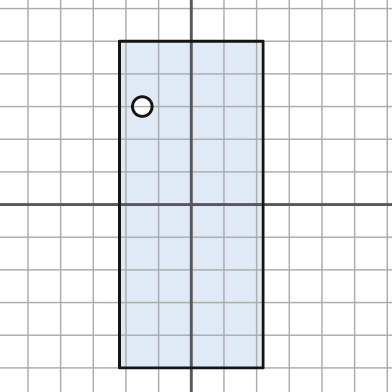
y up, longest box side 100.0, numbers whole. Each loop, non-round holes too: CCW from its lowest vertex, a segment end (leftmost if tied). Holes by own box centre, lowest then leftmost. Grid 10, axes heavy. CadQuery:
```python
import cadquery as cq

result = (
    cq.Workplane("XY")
    .moveTo(-22.0, -50.0)
    .lineTo(22.0, -50.0)
    .lineTo(22.0, 50.0)
    .lineTo(-22.0, 50.0)
    .close()
    .moveTo(-15.0, 30.0)
    .circle(3.0)
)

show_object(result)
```